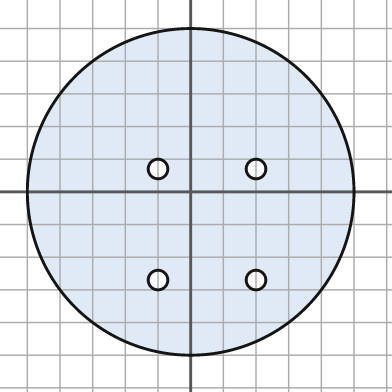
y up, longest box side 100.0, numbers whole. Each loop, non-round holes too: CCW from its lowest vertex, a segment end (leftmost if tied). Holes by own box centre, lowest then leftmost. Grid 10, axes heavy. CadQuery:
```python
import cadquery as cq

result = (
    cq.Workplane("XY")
    .moveTo(0.0, 0.0)
    .circle(50.0)
    .moveTo(-10.0, -27.0)
    .circle(3.0)
    .moveTo(20.0, -27.0)
    .circle(3.0)
    .moveTo(-10.0, 7.0)
    .circle(3.0)
    .moveTo(20.0, 7.0)
    .circle(3.0)
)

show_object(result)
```